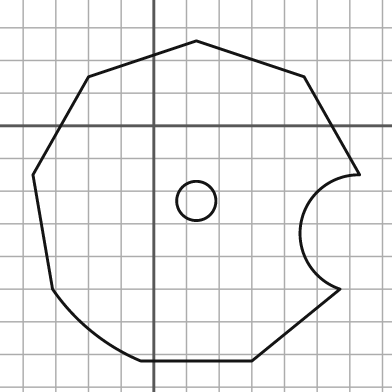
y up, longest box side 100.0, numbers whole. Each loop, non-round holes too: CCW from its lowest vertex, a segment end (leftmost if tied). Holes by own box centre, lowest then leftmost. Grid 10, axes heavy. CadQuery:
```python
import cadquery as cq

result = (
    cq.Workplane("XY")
    .moveTo(-4.0, -72.0)
    .lineTo(30.0, -72.0)
    .lineTo(57.0, -50.0)
    .threePointArc((45.0, -30.0), (63.0, -15.0))
    .lineTo(46.0, 15.0)
    .lineTo(13.0, 26.0)
    .lineTo(-20.0, 15.0)
    .lineTo(-37.0, -15.0)
    .lineTo(-31.0, -50.0)
    .threePointArc((-19.0, -63.0), (-4.0, -72.0))
    .close()
    .moveTo(13.0, -23.0)
    .circle(6.0)
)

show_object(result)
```